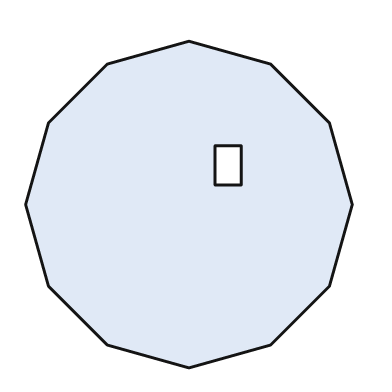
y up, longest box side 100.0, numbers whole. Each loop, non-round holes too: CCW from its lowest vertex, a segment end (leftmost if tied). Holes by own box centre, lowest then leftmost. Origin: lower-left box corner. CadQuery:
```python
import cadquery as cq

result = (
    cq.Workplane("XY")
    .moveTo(50.0, 0.0)
    .lineTo(75.0, 7.0)
    .lineTo(93.0, 25.0)
    .lineTo(100.0, 50.0)
    .lineTo(93.0, 75.0)
    .lineTo(75.0, 93.0)
    .lineTo(50.0, 100.0)
    .lineTo(25.0, 93.0)
    .lineTo(7.0, 75.0)
    .lineTo(0.0, 50.0)
    .lineTo(7.0, 25.0)
    .lineTo(25.0, 7.0)
    .close()
    .moveTo(58.0, 56.0)
    .lineTo(66.0, 56.0)
    .lineTo(66.0, 68.0)
    .lineTo(58.0, 68.0)
    .close()
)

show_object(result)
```